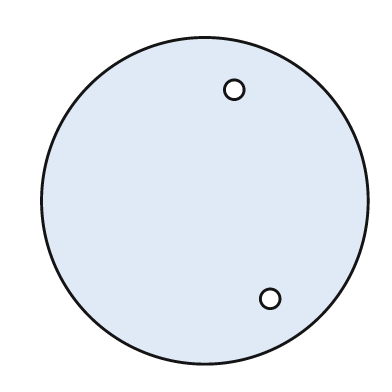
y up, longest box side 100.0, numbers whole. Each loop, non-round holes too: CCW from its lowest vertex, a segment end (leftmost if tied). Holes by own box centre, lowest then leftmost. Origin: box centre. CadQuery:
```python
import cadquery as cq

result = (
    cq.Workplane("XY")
    .moveTo(0.0, 0.0)
    .circle(50.0)
    .moveTo(20.0, -30.0)
    .circle(3.0)
    .moveTo(9.0, 34.0)
    .circle(3.0)
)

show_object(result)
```